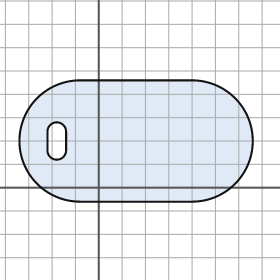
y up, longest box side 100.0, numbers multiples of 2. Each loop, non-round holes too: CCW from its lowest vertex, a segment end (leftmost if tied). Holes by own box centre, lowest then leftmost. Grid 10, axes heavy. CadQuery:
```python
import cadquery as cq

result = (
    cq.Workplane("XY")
    .moveTo(-8.0, -6.0)
    .lineTo(40.0, -6.0)
    .threePointArc((66.0, 20.0), (40.0, 46.0))
    .lineTo(-8.0, 46.0)
    .threePointArc((-34.0, 20.0), (-8.0, -6.0))
    .close()
    .moveTo(-22.0, 16.0)
    .threePointArc((-18.0, 12.0), (-14.0, 16.0))
    .lineTo(-14.0, 24.0)
    .threePointArc((-18.0, 28.0), (-22.0, 24.0))
    .close()
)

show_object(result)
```